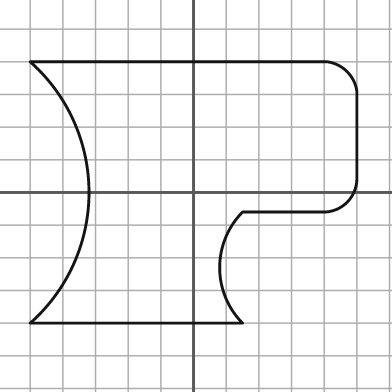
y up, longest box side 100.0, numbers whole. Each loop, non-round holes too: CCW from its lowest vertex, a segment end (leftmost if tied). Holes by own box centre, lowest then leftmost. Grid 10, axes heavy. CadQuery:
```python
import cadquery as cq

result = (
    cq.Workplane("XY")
    .moveTo(-50.0, -40.0)
    .lineTo(15.0, -40.0)
    .threePointArc((8.0, -23.0), (15.0, -6.0))
    .lineTo(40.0, -6.0)
    .threePointArc((47.0, -3.0), (50.0, 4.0))
    .lineTo(50.0, 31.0)
    .threePointArc((47.0, 37.0), (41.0, 40.0))
    .lineTo(-50.0, 40.0)
    .threePointArc((-32.0, 0.0), (-50.0, -40.0))
    .close()
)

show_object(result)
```